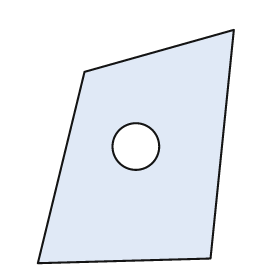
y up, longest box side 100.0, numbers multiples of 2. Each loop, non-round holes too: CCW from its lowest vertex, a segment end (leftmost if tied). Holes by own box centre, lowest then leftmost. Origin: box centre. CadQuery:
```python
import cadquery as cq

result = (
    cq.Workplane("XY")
    .moveTo(-42.0, -50.0)
    .lineTo(32.0, -48.0)
    .lineTo(42.0, 50.0)
    .lineTo(-22.0, 32.0)
    .close()
    .moveTo(0.0, 0.0)
    .circle(10.0)
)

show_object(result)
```